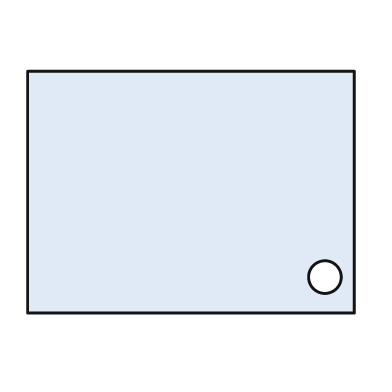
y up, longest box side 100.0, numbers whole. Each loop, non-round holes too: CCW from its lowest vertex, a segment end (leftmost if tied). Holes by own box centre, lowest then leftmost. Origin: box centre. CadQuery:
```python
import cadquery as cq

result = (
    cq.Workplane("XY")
    .moveTo(-50.0, -37.0)
    .lineTo(50.0, -37.0)
    .lineTo(50.0, 37.0)
    .lineTo(-50.0, 37.0)
    .close()
    .moveTo(41.0, -26.0)
    .circle(5.0)
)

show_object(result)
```